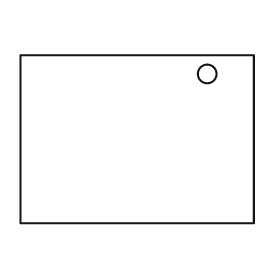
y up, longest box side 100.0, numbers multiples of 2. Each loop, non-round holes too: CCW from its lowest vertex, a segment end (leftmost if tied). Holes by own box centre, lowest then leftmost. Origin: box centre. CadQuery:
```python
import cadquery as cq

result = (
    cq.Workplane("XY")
    .moveTo(-50.0, -36.0)
    .lineTo(50.0, -36.0)
    .lineTo(50.0, 36.0)
    .lineTo(-50.0, 36.0)
    .close()
    .moveTo(30.0, 28.0)
    .circle(4.0)
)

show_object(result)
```